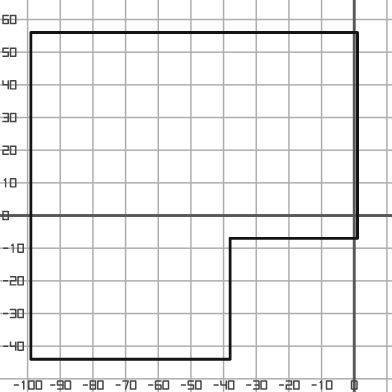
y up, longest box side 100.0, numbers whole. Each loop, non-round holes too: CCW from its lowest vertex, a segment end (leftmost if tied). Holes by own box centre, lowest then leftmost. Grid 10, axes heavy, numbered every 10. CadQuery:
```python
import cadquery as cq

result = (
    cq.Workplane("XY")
    .moveTo(-99.0, -44.0)
    .lineTo(-38.0, -44.0)
    .lineTo(-38.0, -7.0)
    .lineTo(1.0, -7.0)
    .lineTo(1.0, 56.0)
    .lineTo(-99.0, 56.0)
    .close()
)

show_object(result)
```